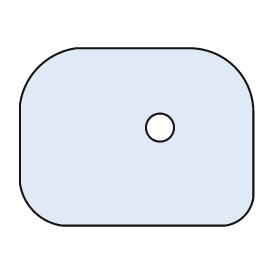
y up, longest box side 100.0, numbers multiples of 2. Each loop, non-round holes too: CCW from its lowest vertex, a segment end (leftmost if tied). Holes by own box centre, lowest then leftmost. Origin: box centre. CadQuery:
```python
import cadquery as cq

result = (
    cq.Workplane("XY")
    .moveTo(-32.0, -38.0)
    .lineTo(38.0, -38.0)
    .threePointArc((46.0, -34.0), (50.0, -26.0))
    .lineTo(50.0, 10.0)
    .threePointArc((42.0, 30.0), (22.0, 38.0))
    .lineTo(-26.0, 38.0)
    .threePointArc((-42.0, 30.0), (-50.0, 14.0))
    .lineTo(-50.0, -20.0)
    .threePointArc((-44.0, -32.0), (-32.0, -38.0))
    .close()
    .moveTo(10.0, 4.0)
    .circle(6.0)
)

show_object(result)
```